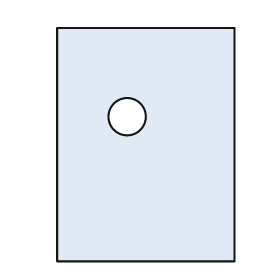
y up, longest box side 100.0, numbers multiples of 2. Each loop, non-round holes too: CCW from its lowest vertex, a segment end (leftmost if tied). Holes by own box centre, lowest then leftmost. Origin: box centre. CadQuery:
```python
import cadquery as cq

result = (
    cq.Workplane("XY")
    .moveTo(-38.0, -50.0)
    .lineTo(38.0, -50.0)
    .lineTo(38.0, 50.0)
    .lineTo(-38.0, 50.0)
    .close()
    .moveTo(-8.0, 12.0)
    .circle(8.0)
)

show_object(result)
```